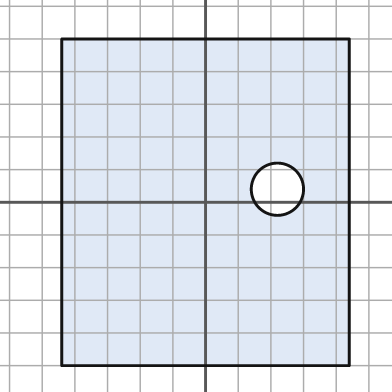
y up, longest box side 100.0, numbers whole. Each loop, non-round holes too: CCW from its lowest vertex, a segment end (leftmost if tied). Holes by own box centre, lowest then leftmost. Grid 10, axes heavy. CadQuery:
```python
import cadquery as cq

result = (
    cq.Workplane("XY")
    .moveTo(-44.0, -50.0)
    .lineTo(44.0, -50.0)
    .lineTo(44.0, 50.0)
    .lineTo(-44.0, 50.0)
    .close()
    .moveTo(22.0, 4.0)
    .circle(8.0)
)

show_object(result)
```